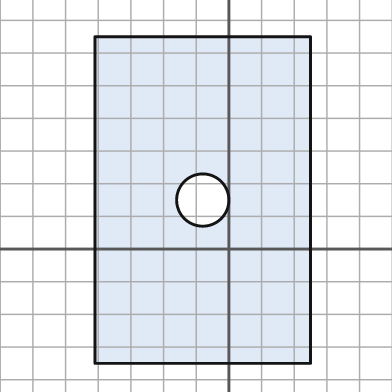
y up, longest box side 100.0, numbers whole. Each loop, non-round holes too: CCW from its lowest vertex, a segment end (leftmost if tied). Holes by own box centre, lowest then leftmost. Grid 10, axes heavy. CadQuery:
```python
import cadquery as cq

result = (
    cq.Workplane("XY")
    .moveTo(-41.0, -35.0)
    .lineTo(25.0, -35.0)
    .lineTo(25.0, 65.0)
    .lineTo(-41.0, 65.0)
    .close()
    .moveTo(-8.0, 15.0)
    .circle(8.0)
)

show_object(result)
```